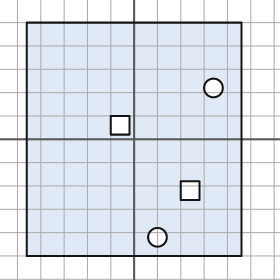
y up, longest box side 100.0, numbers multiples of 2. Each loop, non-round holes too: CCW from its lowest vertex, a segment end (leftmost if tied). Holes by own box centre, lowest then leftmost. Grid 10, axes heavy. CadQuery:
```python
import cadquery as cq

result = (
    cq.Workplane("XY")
    .moveTo(-46.0, -50.0)
    .lineTo(46.0, -50.0)
    .lineTo(46.0, 50.0)
    .lineTo(-46.0, 50.0)
    .close()
    .moveTo(10.0, -42.0)
    .circle(4.0)
    .moveTo(20.0, -26.0)
    .lineTo(28.0, -26.0)
    .lineTo(28.0, -18.0)
    .lineTo(20.0, -18.0)
    .close()
    .moveTo(-10.0, 2.0)
    .lineTo(-2.0, 2.0)
    .lineTo(-2.0, 10.0)
    .lineTo(-10.0, 10.0)
    .close()
    .moveTo(34.0, 22.0)
    .circle(4.0)
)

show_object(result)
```